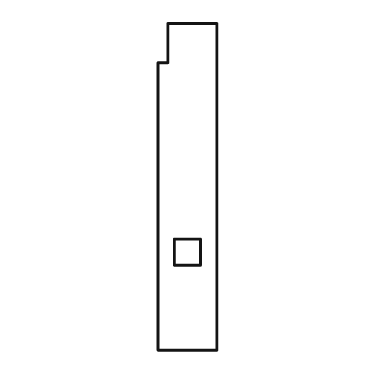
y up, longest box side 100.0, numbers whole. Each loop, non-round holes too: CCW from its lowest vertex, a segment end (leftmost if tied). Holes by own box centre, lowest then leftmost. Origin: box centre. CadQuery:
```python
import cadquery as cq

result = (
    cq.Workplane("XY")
    .moveTo(-9.0, -50.0)
    .lineTo(9.0, -50.0)
    .lineTo(9.0, 50.0)
    .lineTo(-6.0, 50.0)
    .lineTo(-6.0, 38.0)
    .lineTo(-9.0, 38.0)
    .close()
    .moveTo(-4.0, -24.0)
    .lineTo(4.0, -24.0)
    .lineTo(4.0, -16.0)
    .lineTo(-4.0, -16.0)
    .close()
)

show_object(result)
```